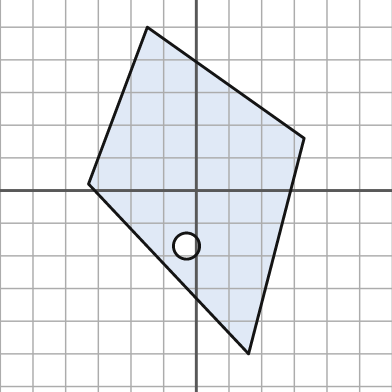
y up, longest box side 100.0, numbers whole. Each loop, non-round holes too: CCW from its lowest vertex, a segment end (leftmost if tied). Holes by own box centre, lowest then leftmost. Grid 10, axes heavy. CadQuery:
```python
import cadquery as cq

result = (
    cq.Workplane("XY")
    .moveTo(16.0, -50.0)
    .lineTo(33.0, 16.0)
    .lineTo(-15.0, 50.0)
    .lineTo(-33.0, 2.0)
    .close()
    .moveTo(-3.0, -17.0)
    .circle(4.0)
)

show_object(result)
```